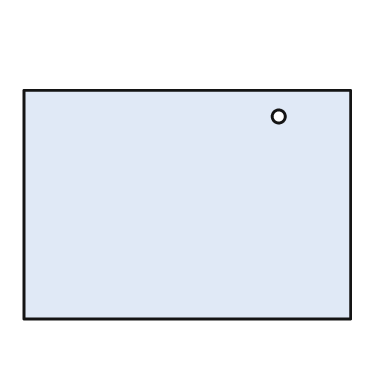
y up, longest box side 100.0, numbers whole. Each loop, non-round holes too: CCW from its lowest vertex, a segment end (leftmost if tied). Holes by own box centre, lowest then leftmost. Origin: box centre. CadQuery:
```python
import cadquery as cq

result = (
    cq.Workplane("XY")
    .moveTo(-50.0, -35.0)
    .lineTo(50.0, -35.0)
    .lineTo(50.0, 35.0)
    .lineTo(-50.0, 35.0)
    .close()
    .moveTo(28.0, 27.0)
    .circle(2.0)
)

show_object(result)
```